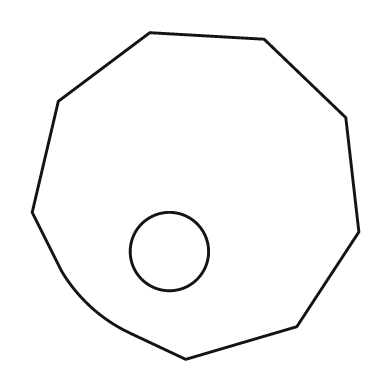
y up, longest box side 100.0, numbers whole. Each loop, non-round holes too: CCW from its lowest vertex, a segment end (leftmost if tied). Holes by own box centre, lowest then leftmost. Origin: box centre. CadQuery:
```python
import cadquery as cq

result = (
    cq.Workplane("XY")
    .moveTo(-3.0, -50.0)
    .lineTo(31.0, -40.0)
    .lineTo(50.0, -11.0)
    .lineTo(46.0, 24.0)
    .lineTo(21.0, 48.0)
    .lineTo(-14.0, 50.0)
    .lineTo(-42.0, 29.0)
    .lineTo(-50.0, -5.0)
    .lineTo(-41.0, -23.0)
    .threePointArc((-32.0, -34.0), (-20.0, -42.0))
    .close()
    .moveTo(-8.0, -17.0)
    .circle(12.0)
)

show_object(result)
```